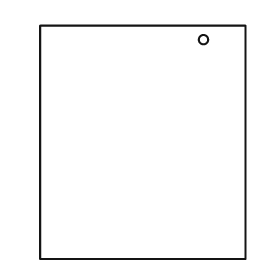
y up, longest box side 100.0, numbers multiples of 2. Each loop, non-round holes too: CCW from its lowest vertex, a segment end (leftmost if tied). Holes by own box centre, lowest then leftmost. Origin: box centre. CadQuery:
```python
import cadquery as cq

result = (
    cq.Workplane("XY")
    .moveTo(-44.0, -50.0)
    .lineTo(44.0, -50.0)
    .lineTo(44.0, 50.0)
    .lineTo(-44.0, 50.0)
    .close()
    .moveTo(26.0, 44.0)
    .circle(2.0)
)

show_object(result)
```